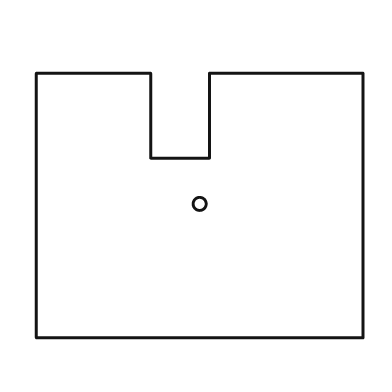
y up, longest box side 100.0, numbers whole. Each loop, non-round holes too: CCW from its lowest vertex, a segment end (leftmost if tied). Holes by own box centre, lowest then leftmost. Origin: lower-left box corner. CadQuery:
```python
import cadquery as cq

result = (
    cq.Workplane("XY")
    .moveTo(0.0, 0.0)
    .lineTo(100.0, 0.0)
    .lineTo(100.0, 81.0)
    .lineTo(53.0, 81.0)
    .lineTo(53.0, 55.0)
    .lineTo(35.0, 55.0)
    .lineTo(35.0, 81.0)
    .lineTo(0.0, 81.0)
    .close()
    .moveTo(50.0, 41.0)
    .circle(2.0)
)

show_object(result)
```